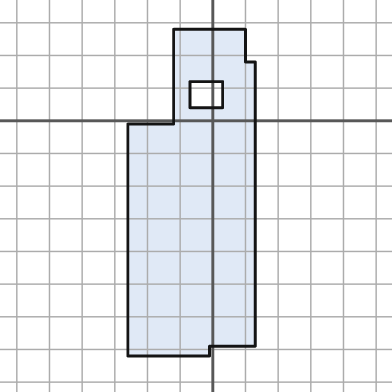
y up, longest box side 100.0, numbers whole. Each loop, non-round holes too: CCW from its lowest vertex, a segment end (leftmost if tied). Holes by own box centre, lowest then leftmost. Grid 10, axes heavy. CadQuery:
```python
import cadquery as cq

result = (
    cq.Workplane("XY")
    .moveTo(-26.0, -72.0)
    .lineTo(-1.0, -72.0)
    .lineTo(-1.0, -69.0)
    .lineTo(13.0, -69.0)
    .lineTo(13.0, 18.0)
    .lineTo(10.0, 18.0)
    .lineTo(10.0, 28.0)
    .lineTo(-12.0, 28.0)
    .lineTo(-12.0, -1.0)
    .lineTo(-26.0, -1.0)
    .close()
    .moveTo(-7.0, 4.0)
    .lineTo(3.0, 4.0)
    .lineTo(3.0, 12.0)
    .lineTo(-7.0, 12.0)
    .close()
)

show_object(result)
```